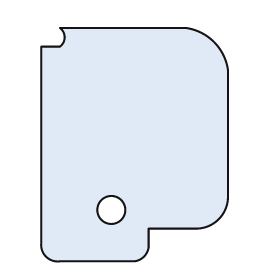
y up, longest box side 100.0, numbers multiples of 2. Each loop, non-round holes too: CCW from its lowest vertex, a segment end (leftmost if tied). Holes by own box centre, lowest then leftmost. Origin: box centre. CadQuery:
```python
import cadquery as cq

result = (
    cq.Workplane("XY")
    .moveTo(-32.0, -50.0)
    .lineTo(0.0, -50.0)
    .threePointArc((4.0, -48.0), (6.0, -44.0))
    .lineTo(6.0, -36.0)
    .lineTo(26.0, -36.0)
    .threePointArc((36.0, -32.0), (40.0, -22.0))
    .lineTo(40.0, 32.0)
    .threePointArc((34.0, 44.0), (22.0, 50.0))
    .lineTo(-32.0, 50.0)
    .threePointArc((-30.0, 46.0), (-32.0, 42.0))
    .lineTo(-40.0, 42.0)
    .lineTo(-40.0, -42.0)
    .threePointArc((-38.0, -48.0), (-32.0, -50.0))
    .close()
    .moveTo(-10.0, -28.0)
    .circle(6.0)
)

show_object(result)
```